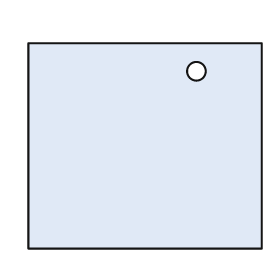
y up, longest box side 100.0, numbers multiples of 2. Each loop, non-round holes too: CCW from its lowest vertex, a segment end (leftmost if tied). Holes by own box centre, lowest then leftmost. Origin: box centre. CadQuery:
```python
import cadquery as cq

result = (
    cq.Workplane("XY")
    .moveTo(-50.0, -44.0)
    .lineTo(50.0, -44.0)
    .lineTo(50.0, 44.0)
    .lineTo(-50.0, 44.0)
    .close()
    .moveTo(22.0, 32.0)
    .circle(4.0)
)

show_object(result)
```